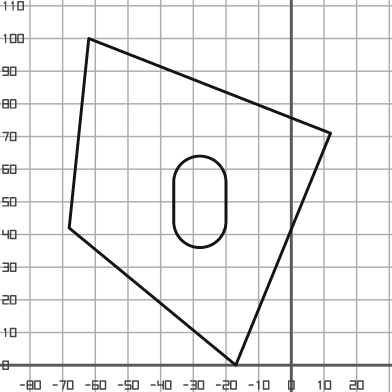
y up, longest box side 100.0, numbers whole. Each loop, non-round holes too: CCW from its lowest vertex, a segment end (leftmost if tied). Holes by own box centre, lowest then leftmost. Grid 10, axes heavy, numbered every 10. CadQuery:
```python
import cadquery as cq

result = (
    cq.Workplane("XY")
    .moveTo(-17.0, 0.0)
    .lineTo(12.0, 71.0)
    .lineTo(-62.0, 100.0)
    .lineTo(-68.0, 42.0)
    .close()
    .moveTo(-36.0, 44.0)
    .threePointArc((-28.0, 36.0), (-20.0, 44.0))
    .lineTo(-20.0, 56.0)
    .threePointArc((-28.0, 64.0), (-36.0, 56.0))
    .close()
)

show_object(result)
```